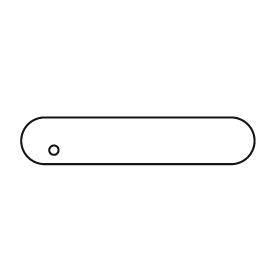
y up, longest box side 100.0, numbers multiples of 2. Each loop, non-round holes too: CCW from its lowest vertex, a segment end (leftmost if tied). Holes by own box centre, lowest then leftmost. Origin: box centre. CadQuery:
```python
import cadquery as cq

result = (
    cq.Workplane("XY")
    .moveTo(-40.0, -10.0)
    .lineTo(40.0, -10.0)
    .threePointArc((50.0, 0.0), (40.0, 10.0))
    .lineTo(-40.0, 10.0)
    .threePointArc((-50.0, 0.0), (-40.0, -10.0))
    .close()
    .moveTo(-36.0, -4.0)
    .circle(2.0)
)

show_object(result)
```